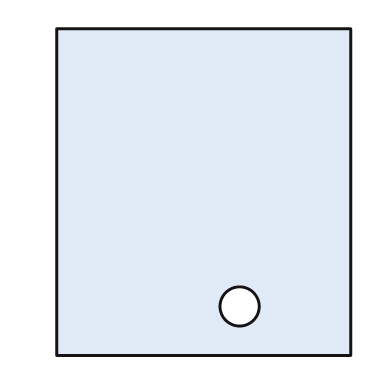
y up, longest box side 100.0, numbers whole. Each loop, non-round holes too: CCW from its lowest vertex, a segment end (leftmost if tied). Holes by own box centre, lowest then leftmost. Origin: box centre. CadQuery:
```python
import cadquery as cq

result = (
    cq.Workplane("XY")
    .moveTo(-45.0, -50.0)
    .lineTo(45.0, -50.0)
    .lineTo(45.0, 50.0)
    .lineTo(-45.0, 50.0)
    .close()
    .moveTo(11.0, -35.0)
    .circle(6.0)
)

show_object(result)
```